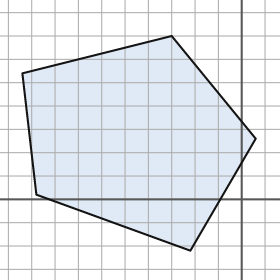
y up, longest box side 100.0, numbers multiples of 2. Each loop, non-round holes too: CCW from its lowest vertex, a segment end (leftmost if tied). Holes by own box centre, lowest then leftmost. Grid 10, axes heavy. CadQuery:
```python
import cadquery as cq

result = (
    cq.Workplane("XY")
    .moveTo(-22.0, -22.0)
    .lineTo(6.0, 26.0)
    .lineTo(-30.0, 70.0)
    .lineTo(-94.0, 54.0)
    .lineTo(-88.0, 2.0)
    .close()
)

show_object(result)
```